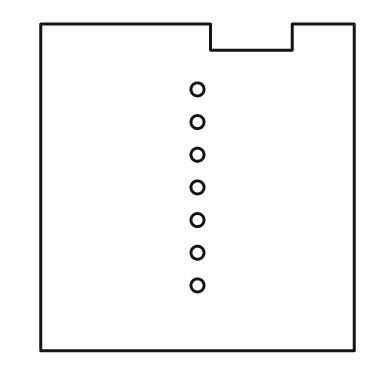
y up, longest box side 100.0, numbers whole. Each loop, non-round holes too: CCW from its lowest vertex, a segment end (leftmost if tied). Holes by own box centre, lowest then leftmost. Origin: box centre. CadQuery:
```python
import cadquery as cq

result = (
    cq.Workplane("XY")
    .moveTo(-48.0, -50.0)
    .lineTo(48.0, -50.0)
    .lineTo(48.0, 50.0)
    .lineTo(29.0, 50.0)
    .lineTo(29.0, 42.0)
    .lineTo(4.0, 42.0)
    .lineTo(4.0, 50.0)
    .lineTo(-48.0, 50.0)
    .close()
    .moveTo(0.0, -30.0)
    .circle(2.0)
    .moveTo(0.0, -20.0)
    .circle(2.0)
    .moveTo(0.0, -10.0)
    .circle(2.0)
    .moveTo(0.0, 0.0)
    .circle(2.0)
    .moveTo(0.0, 10.0)
    .circle(2.0)
    .moveTo(0.0, 20.0)
    .circle(2.0)
    .moveTo(0.0, 30.0)
    .circle(2.0)
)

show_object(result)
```